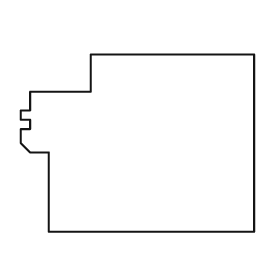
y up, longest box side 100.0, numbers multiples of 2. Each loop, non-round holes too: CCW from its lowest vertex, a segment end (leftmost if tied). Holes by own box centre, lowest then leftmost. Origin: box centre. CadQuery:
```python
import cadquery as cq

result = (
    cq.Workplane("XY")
    .moveTo(-38.0, -38.0)
    .lineTo(50.0, -38.0)
    .lineTo(50.0, 38.0)
    .lineTo(-20.0, 38.0)
    .lineTo(-20.0, 22.0)
    .lineTo(-46.0, 22.0)
    .lineTo(-46.0, 14.0)
    .lineTo(-50.0, 14.0)
    .lineTo(-50.0, 10.0)
    .lineTo(-46.0, 10.0)
    .lineTo(-46.0, 6.0)
    .lineTo(-50.0, 6.0)
    .lineTo(-50.0, 0.0)
    .lineTo(-46.0, -4.0)
    .lineTo(-38.0, -4.0)
    .close()
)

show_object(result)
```